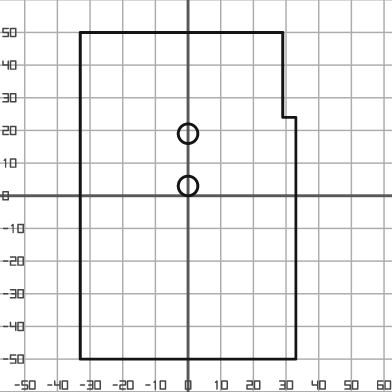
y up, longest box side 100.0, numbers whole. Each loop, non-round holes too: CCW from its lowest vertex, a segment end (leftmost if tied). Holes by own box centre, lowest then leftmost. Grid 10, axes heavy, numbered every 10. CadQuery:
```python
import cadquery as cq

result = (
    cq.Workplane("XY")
    .moveTo(-33.0, -50.0)
    .lineTo(33.0, -50.0)
    .lineTo(33.0, 24.0)
    .lineTo(29.0, 24.0)
    .lineTo(29.0, 50.0)
    .lineTo(-33.0, 50.0)
    .close()
    .moveTo(0.0, 3.0)
    .circle(3.0)
    .moveTo(0.0, 19.0)
    .circle(3.0)
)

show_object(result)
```